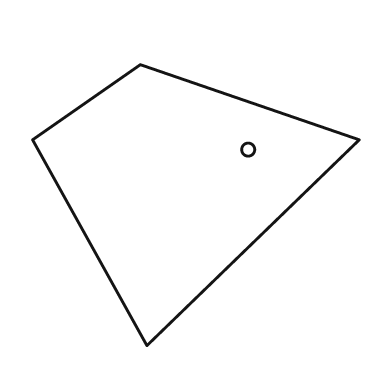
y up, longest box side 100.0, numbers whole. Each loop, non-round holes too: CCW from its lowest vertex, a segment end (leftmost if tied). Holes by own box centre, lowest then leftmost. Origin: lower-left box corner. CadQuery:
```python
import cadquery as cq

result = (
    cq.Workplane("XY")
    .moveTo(35.0, 0.0)
    .lineTo(100.0, 63.0)
    .lineTo(33.0, 86.0)
    .lineTo(0.0, 63.0)
    .close()
    .moveTo(66.0, 60.0)
    .circle(2.0)
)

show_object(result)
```